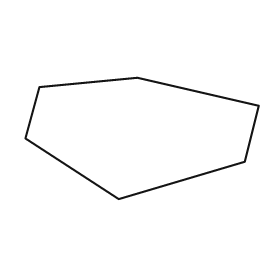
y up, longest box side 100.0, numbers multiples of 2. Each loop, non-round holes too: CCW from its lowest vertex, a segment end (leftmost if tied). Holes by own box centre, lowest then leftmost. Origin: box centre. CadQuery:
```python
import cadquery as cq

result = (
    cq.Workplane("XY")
    .moveTo(-10.0, -26.0)
    .lineTo(44.0, -10.0)
    .lineTo(50.0, 14.0)
    .lineTo(-2.0, 26.0)
    .lineTo(-44.0, 22.0)
    .lineTo(-50.0, 0.0)
    .close()
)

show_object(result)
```